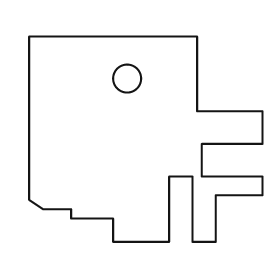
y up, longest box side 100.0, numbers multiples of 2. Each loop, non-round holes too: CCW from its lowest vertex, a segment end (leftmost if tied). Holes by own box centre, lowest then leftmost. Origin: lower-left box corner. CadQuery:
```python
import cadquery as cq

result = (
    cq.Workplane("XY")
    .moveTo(36.0, 0.0)
    .lineTo(60.0, 0.0)
    .lineTo(60.0, 28.0)
    .lineTo(70.0, 28.0)
    .lineTo(70.0, 0.0)
    .lineTo(80.0, 0.0)
    .lineTo(80.0, 20.0)
    .lineTo(100.0, 20.0)
    .lineTo(100.0, 28.0)
    .lineTo(74.0, 28.0)
    .lineTo(74.0, 42.0)
    .lineTo(100.0, 42.0)
    .lineTo(100.0, 56.0)
    .lineTo(72.0, 56.0)
    .lineTo(72.0, 88.0)
    .lineTo(0.0, 88.0)
    .lineTo(0.0, 18.0)
    .lineTo(6.0, 14.0)
    .lineTo(18.0, 14.0)
    .lineTo(18.0, 10.0)
    .lineTo(36.0, 10.0)
    .close()
    .moveTo(42.0, 70.0)
    .circle(6.0)
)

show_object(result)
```